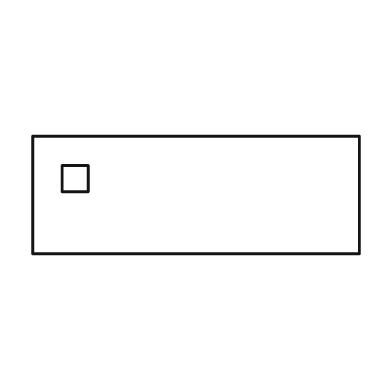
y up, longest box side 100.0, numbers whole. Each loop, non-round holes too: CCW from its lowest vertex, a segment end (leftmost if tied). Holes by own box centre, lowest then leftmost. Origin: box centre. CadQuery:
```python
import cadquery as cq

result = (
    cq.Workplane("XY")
    .moveTo(-50.0, -18.0)
    .lineTo(50.0, -18.0)
    .lineTo(50.0, 18.0)
    .lineTo(-50.0, 18.0)
    .close()
    .moveTo(-41.0, 1.0)
    .lineTo(-33.0, 1.0)
    .lineTo(-33.0, 9.0)
    .lineTo(-41.0, 9.0)
    .close()
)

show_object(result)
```